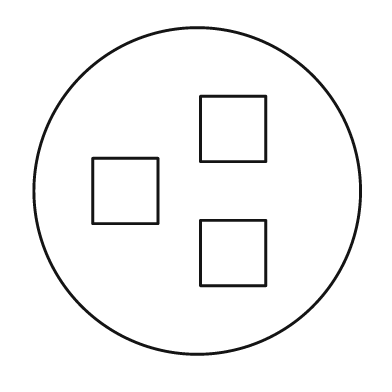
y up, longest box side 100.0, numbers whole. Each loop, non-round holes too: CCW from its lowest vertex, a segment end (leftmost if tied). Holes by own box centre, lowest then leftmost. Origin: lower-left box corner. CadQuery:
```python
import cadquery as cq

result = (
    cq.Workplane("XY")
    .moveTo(50.0, 50.0)
    .circle(50.0)
    .moveTo(51.0, 21.0)
    .lineTo(71.0, 21.0)
    .lineTo(71.0, 41.0)
    .lineTo(51.0, 41.0)
    .close()
    .moveTo(18.0, 40.0)
    .lineTo(38.0, 40.0)
    .lineTo(38.0, 60.0)
    .lineTo(18.0, 60.0)
    .close()
    .moveTo(51.0, 59.0)
    .lineTo(71.0, 59.0)
    .lineTo(71.0, 79.0)
    .lineTo(51.0, 79.0)
    .close()
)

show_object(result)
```